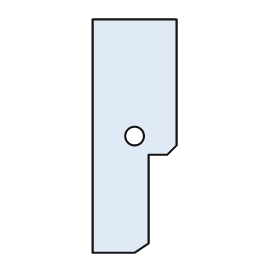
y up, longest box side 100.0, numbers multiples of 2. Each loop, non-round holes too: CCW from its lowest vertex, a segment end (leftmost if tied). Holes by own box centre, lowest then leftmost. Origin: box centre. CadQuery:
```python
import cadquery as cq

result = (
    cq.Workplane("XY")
    .moveTo(-18.0, -50.0)
    .lineTo(0.0, -50.0)
    .lineTo(6.0, -46.0)
    .lineTo(6.0, -8.0)
    .lineTo(14.0, -8.0)
    .lineTo(18.0, -4.0)
    .lineTo(18.0, 50.0)
    .lineTo(-18.0, 50.0)
    .close()
    .moveTo(0.0, 0.0)
    .circle(4.0)
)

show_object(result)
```